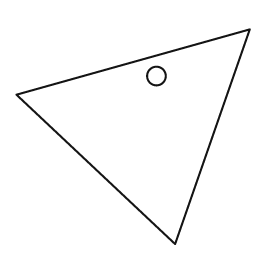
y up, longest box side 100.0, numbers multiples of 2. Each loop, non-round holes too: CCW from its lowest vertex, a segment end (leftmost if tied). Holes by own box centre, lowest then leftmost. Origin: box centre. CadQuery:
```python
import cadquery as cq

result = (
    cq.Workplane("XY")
    .moveTo(18.0, -46.0)
    .lineTo(50.0, 46.0)
    .lineTo(-50.0, 18.0)
    .close()
    .moveTo(10.0, 26.0)
    .circle(4.0)
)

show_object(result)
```